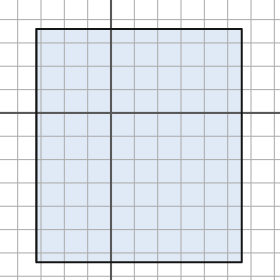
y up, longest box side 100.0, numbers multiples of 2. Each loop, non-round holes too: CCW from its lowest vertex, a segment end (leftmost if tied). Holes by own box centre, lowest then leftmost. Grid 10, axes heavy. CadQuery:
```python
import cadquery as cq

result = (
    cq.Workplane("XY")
    .moveTo(-32.0, -64.0)
    .lineTo(56.0, -64.0)
    .lineTo(56.0, 36.0)
    .lineTo(-32.0, 36.0)
    .close()
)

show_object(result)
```